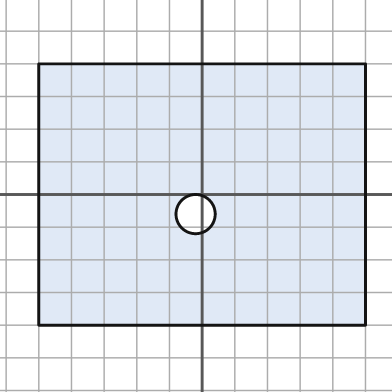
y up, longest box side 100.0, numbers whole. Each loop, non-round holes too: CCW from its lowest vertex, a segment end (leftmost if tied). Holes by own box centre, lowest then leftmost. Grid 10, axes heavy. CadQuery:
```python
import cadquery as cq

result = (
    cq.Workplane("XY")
    .moveTo(-50.0, -40.0)
    .lineTo(50.0, -40.0)
    .lineTo(50.0, 40.0)
    .lineTo(-50.0, 40.0)
    .close()
    .moveTo(-2.0, -6.0)
    .circle(6.0)
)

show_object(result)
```